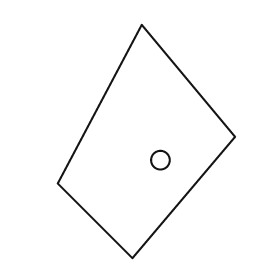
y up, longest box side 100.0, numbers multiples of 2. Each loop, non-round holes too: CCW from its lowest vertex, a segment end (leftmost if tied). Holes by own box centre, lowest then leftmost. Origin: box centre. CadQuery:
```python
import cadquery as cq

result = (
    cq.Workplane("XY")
    .moveTo(-6.0, -50.0)
    .lineTo(38.0, 2.0)
    .lineTo(-2.0, 50.0)
    .lineTo(-38.0, -18.0)
    .close()
    .moveTo(6.0, -8.0)
    .circle(4.0)
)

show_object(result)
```